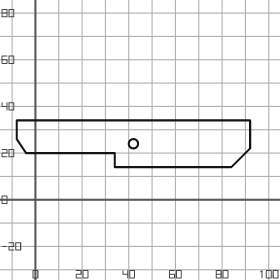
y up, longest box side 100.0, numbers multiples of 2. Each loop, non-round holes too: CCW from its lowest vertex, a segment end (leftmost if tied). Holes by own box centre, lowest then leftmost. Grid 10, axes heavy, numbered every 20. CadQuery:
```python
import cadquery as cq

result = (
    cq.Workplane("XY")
    .moveTo(34.0, 14.0)
    .lineTo(84.0, 14.0)
    .lineTo(92.0, 22.0)
    .lineTo(92.0, 34.0)
    .lineTo(-8.0, 34.0)
    .lineTo(-8.0, 26.0)
    .lineTo(-4.0, 20.0)
    .lineTo(34.0, 20.0)
    .close()
    .moveTo(42.0, 24.0)
    .circle(2.0)
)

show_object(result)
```